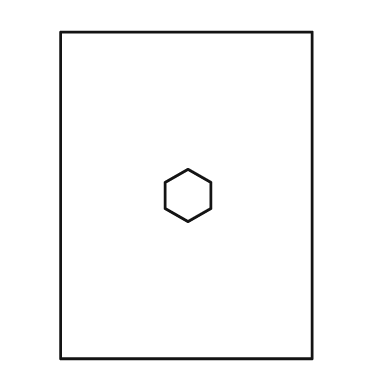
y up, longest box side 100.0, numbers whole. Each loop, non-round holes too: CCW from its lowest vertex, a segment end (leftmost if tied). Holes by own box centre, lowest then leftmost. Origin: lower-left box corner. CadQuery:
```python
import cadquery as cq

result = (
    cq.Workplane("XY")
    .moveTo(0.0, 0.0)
    .lineTo(77.0, 0.0)
    .lineTo(77.0, 100.0)
    .lineTo(0.0, 100.0)
    .close()
    .moveTo(39.0, 42.0)
    .lineTo(46.0, 46.0)
    .lineTo(46.0, 54.0)
    .lineTo(39.0, 58.0)
    .lineTo(32.0, 54.0)
    .lineTo(32.0, 46.0)
    .close()
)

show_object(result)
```